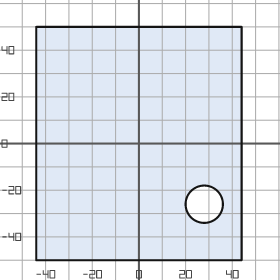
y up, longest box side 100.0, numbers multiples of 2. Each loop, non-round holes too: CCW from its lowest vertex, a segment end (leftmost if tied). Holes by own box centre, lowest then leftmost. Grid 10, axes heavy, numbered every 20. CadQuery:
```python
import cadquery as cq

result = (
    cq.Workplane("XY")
    .moveTo(-44.0, -50.0)
    .lineTo(44.0, -50.0)
    .lineTo(44.0, 50.0)
    .lineTo(-44.0, 50.0)
    .close()
    .moveTo(28.0, -26.0)
    .circle(8.0)
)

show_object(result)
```